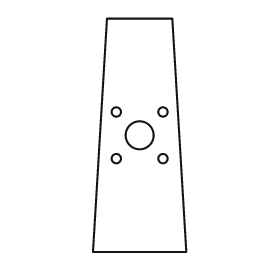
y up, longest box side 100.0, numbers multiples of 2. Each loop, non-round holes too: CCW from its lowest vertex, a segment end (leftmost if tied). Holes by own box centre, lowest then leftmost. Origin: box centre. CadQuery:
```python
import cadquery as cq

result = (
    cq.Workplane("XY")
    .moveTo(-20.0, -50.0)
    .lineTo(20.0, -50.0)
    .lineTo(14.0, 50.0)
    .lineTo(-14.0, 50.0)
    .close()
    .moveTo(-10.0, -10.0)
    .circle(2.0)
    .moveTo(10.0, -10.0)
    .circle(2.0)
    .moveTo(0.0, 0.0)
    .circle(6.0)
    .moveTo(-10.0, 10.0)
    .circle(2.0)
    .moveTo(10.0, 10.0)
    .circle(2.0)
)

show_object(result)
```